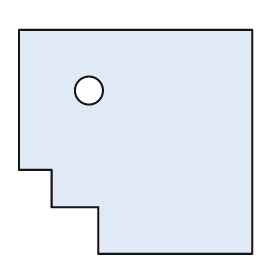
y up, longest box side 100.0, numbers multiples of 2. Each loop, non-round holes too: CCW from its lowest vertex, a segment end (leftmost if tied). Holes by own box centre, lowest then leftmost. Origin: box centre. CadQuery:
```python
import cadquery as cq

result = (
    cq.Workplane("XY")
    .moveTo(-16.0, -48.0)
    .lineTo(50.0, -48.0)
    .lineTo(50.0, 48.0)
    .lineTo(-50.0, 48.0)
    .lineTo(-50.0, -12.0)
    .lineTo(-36.0, -12.0)
    .lineTo(-36.0, -28.0)
    .lineTo(-16.0, -28.0)
    .close()
    .moveTo(-20.0, 22.0)
    .circle(6.0)
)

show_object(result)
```